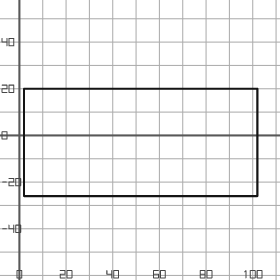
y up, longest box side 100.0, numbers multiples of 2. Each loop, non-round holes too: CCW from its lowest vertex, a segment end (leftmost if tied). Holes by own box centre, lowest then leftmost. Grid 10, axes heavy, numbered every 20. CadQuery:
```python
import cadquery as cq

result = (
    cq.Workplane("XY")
    .moveTo(2.0, -26.0)
    .lineTo(102.0, -26.0)
    .lineTo(102.0, 20.0)
    .lineTo(2.0, 20.0)
    .close()
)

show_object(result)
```